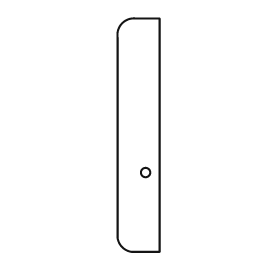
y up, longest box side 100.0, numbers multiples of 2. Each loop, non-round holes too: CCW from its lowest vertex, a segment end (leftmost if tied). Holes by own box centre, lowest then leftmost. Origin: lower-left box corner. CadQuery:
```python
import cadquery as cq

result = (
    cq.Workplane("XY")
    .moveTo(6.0, 0.0)
    .lineTo(18.0, 0.0)
    .lineTo(18.0, 100.0)
    .lineTo(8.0, 100.0)
    .threePointArc((2.0, 98.0), (0.0, 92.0))
    .lineTo(0.0, 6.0)
    .threePointArc((2.0, 2.0), (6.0, 0.0))
    .close()
    .moveTo(12.0, 34.0)
    .circle(2.0)
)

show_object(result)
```